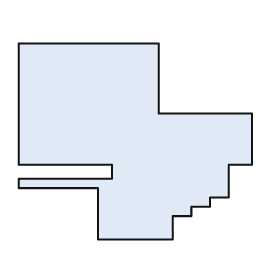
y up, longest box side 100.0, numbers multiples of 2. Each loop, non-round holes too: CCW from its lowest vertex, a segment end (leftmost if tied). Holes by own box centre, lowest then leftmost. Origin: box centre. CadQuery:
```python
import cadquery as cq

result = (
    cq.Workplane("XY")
    .moveTo(-16.0, -42.0)
    .lineTo(16.0, -42.0)
    .lineTo(16.0, -32.0)
    .lineTo(24.0, -32.0)
    .lineTo(24.0, -28.0)
    .lineTo(32.0, -28.0)
    .lineTo(32.0, -24.0)
    .lineTo(40.0, -24.0)
    .lineTo(40.0, -10.0)
    .lineTo(50.0, -10.0)
    .lineTo(50.0, 12.0)
    .lineTo(10.0, 12.0)
    .lineTo(10.0, 42.0)
    .lineTo(-50.0, 42.0)
    .lineTo(-50.0, -10.0)
    .lineTo(-10.0, -10.0)
    .lineTo(-10.0, -16.0)
    .lineTo(-50.0, -16.0)
    .lineTo(-50.0, -20.0)
    .lineTo(-16.0, -20.0)
    .close()
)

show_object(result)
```